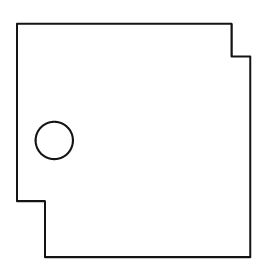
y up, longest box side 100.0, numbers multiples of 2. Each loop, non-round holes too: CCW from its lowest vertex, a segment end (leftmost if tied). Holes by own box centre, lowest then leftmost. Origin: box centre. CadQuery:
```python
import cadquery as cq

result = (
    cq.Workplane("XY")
    .moveTo(-38.0, -50.0)
    .lineTo(50.0, -50.0)
    .lineTo(50.0, 36.0)
    .lineTo(42.0, 36.0)
    .lineTo(42.0, 50.0)
    .lineTo(-50.0, 50.0)
    .lineTo(-50.0, -26.0)
    .lineTo(-38.0, -26.0)
    .close()
    .moveTo(-34.0, 0.0)
    .circle(8.0)
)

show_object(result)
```